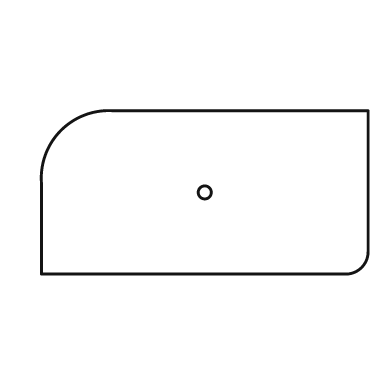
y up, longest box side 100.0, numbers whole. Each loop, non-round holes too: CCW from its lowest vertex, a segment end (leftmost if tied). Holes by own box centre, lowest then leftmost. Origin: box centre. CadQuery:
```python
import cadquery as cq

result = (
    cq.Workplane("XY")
    .moveTo(-50.0, -25.0)
    .lineTo(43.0, -25.0)
    .threePointArc((48.0, -23.0), (50.0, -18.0))
    .lineTo(50.0, 25.0)
    .lineTo(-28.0, 25.0)
    .threePointArc((-44.0, 19.0), (-50.0, 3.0))
    .close()
    .moveTo(0.0, 0.0)
    .circle(2.0)
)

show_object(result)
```